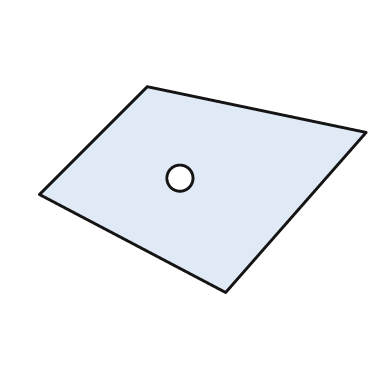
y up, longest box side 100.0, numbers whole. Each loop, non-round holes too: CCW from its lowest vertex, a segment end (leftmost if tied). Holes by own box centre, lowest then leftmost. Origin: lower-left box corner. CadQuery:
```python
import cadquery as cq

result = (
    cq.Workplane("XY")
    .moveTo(57.0, 0.0)
    .lineTo(100.0, 49.0)
    .lineTo(33.0, 63.0)
    .lineTo(0.0, 30.0)
    .close()
    .moveTo(43.0, 35.0)
    .circle(4.0)
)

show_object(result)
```